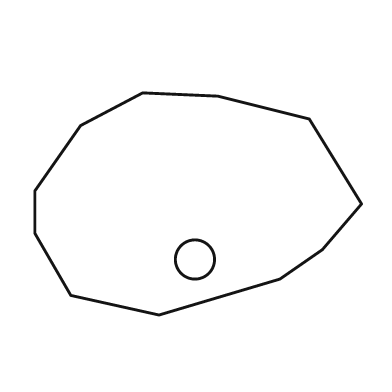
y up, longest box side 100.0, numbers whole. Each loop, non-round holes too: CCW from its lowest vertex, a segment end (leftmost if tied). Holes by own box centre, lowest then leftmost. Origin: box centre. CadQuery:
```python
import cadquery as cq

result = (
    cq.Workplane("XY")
    .moveTo(-12.0, -34.0)
    .lineTo(25.0, -23.0)
    .lineTo(38.0, -14.0)
    .lineTo(50.0, 0.0)
    .lineTo(34.0, 26.0)
    .lineTo(6.0, 33.0)
    .lineTo(-17.0, 34.0)
    .lineTo(-36.0, 24.0)
    .lineTo(-50.0, 4.0)
    .lineTo(-50.0, -9.0)
    .lineTo(-39.0, -28.0)
    .close()
    .moveTo(-1.0, -17.0)
    .circle(6.0)
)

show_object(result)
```